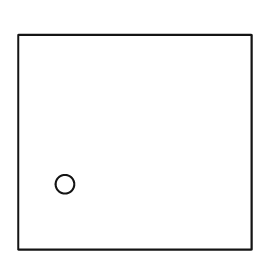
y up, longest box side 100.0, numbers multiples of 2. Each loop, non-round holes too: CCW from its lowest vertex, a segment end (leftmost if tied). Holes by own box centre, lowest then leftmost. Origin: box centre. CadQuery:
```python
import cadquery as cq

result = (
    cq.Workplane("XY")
    .moveTo(-50.0, -46.0)
    .lineTo(50.0, -46.0)
    .lineTo(50.0, 46.0)
    .lineTo(-50.0, 46.0)
    .close()
    .moveTo(-30.0, -18.0)
    .circle(4.0)
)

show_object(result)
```